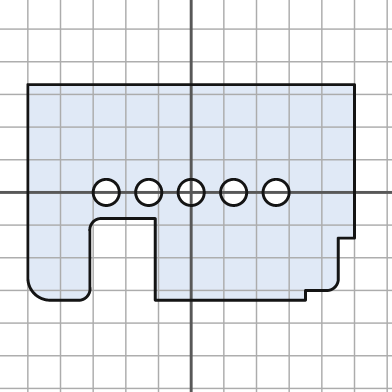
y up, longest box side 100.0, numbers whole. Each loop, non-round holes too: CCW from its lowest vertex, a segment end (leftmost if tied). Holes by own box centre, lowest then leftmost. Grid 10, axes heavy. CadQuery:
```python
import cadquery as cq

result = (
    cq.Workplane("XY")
    .moveTo(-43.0, -33.0)
    .lineTo(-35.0, -33.0)
    .threePointArc((-32.0, -32.0), (-31.0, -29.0))
    .lineTo(-31.0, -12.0)
    .threePointArc((-30.0, -9.0), (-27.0, -8.0))
    .lineTo(-11.0, -8.0)
    .lineTo(-11.0, -33.0)
    .lineTo(35.0, -33.0)
    .lineTo(35.0, -30.0)
    .lineTo(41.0, -30.0)
    .threePointArc((44.0, -29.0), (45.0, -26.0))
    .lineTo(45.0, -14.0)
    .lineTo(50.0, -14.0)
    .lineTo(50.0, 33.0)
    .lineTo(-50.0, 33.0)
    .lineTo(-50.0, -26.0)
    .threePointArc((-48.0, -31.0), (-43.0, -33.0))
    .close()
    .moveTo(-26.0, 0.0)
    .circle(4.0)
    .moveTo(-13.0, 0.0)
    .circle(4.0)
    .moveTo(0.0, 0.0)
    .circle(4.0)
    .moveTo(13.0, 0.0)
    .circle(4.0)
    .moveTo(26.0, 0.0)
    .circle(4.0)
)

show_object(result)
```